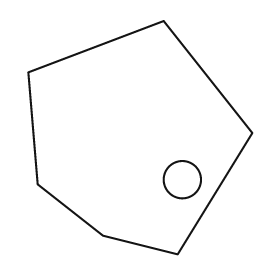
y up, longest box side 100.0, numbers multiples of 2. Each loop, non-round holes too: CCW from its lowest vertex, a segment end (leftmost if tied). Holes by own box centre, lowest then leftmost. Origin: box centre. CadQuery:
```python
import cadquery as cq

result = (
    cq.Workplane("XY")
    .moveTo(16.0, -50.0)
    .lineTo(48.0, 2.0)
    .lineTo(10.0, 50.0)
    .lineTo(-48.0, 28.0)
    .lineTo(-44.0, -20.0)
    .lineTo(-16.0, -42.0)
    .close()
    .moveTo(18.0, -18.0)
    .circle(8.0)
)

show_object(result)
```